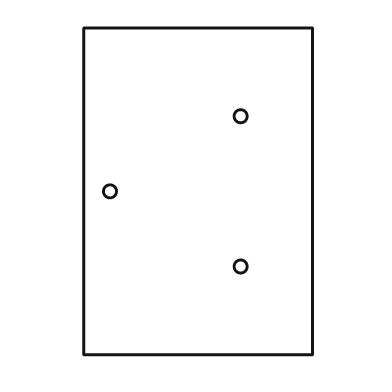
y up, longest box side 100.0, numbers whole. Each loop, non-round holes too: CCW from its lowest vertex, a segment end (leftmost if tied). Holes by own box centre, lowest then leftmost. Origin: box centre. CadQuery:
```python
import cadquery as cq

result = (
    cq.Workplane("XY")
    .moveTo(-35.0, -50.0)
    .lineTo(35.0, -50.0)
    .lineTo(35.0, 50.0)
    .lineTo(-35.0, 50.0)
    .close()
    .moveTo(13.0, -23.0)
    .circle(2.0)
    .moveTo(-27.0, 0.0)
    .circle(2.0)
    .moveTo(13.0, 23.0)
    .circle(2.0)
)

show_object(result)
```